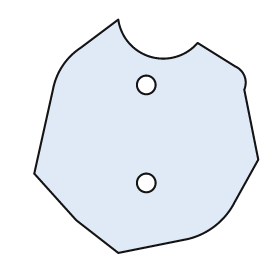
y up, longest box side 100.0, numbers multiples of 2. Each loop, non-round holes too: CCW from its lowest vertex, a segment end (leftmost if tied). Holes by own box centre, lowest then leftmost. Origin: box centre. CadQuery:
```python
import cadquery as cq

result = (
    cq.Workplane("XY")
    .moveTo(-12.0, -50.0)
    .lineTo(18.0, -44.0)
    .threePointArc((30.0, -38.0), (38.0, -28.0))
    .lineTo(48.0, -10.0)
    .lineTo(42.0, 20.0)
    .threePointArc((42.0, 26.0), (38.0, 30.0))
    .lineTo(22.0, 40.0)
    .threePointArc((2.0, 34.0), (-12.0, 50.0))
    .lineTo(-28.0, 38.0)
    .threePointArc((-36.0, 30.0), (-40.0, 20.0))
    .lineTo(-48.0, -16.0)
    .lineTo(-30.0, -36.0)
    .close()
    .moveTo(0.0, -20.0)
    .circle(4.0)
    .moveTo(0.0, 22.0)
    .circle(4.0)
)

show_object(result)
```